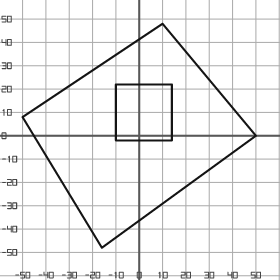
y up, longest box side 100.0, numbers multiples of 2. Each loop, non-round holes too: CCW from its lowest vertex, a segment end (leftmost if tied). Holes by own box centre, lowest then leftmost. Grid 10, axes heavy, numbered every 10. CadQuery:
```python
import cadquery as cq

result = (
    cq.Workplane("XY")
    .moveTo(-16.0, -48.0)
    .lineTo(50.0, 0.0)
    .lineTo(10.0, 48.0)
    .lineTo(-50.0, 8.0)
    .close()
    .moveTo(-10.0, -2.0)
    .lineTo(14.0, -2.0)
    .lineTo(14.0, 22.0)
    .lineTo(-10.0, 22.0)
    .close()
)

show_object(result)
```